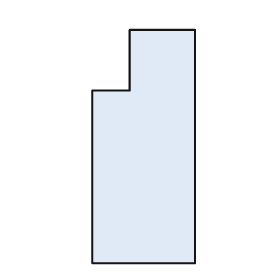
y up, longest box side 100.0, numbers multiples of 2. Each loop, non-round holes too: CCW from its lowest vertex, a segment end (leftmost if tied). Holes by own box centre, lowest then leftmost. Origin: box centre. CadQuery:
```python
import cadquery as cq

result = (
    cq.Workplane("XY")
    .moveTo(-22.0, -50.0)
    .lineTo(22.0, -50.0)
    .lineTo(22.0, 50.0)
    .lineTo(-6.0, 50.0)
    .lineTo(-6.0, 24.0)
    .lineTo(-22.0, 24.0)
    .close()
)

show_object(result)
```